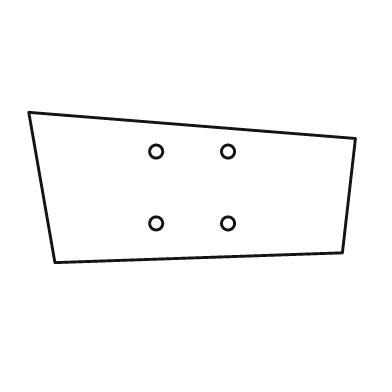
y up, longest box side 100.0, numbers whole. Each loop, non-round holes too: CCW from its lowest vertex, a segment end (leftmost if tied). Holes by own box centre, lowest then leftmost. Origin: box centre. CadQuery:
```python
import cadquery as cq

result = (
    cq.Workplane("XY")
    .moveTo(-42.0, -23.0)
    .lineTo(46.0, -20.0)
    .lineTo(50.0, 15.0)
    .lineTo(-50.0, 23.0)
    .close()
    .moveTo(-11.0, -11.0)
    .circle(2.0)
    .moveTo(11.0, -11.0)
    .circle(2.0)
    .moveTo(-11.0, 11.0)
    .circle(2.0)
    .moveTo(11.0, 11.0)
    .circle(2.0)
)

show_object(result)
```